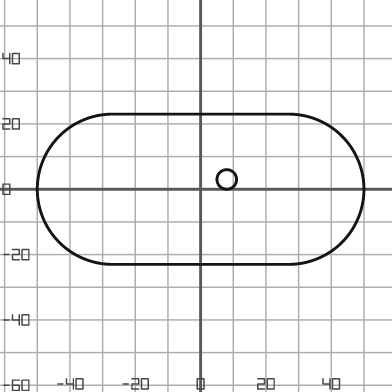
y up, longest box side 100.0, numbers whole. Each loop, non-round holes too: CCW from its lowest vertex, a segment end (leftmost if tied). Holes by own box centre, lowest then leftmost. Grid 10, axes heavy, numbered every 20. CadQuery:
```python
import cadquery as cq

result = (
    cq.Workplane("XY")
    .moveTo(-27.0, -23.0)
    .lineTo(27.0, -23.0)
    .threePointArc((50.0, 0.0), (27.0, 23.0))
    .lineTo(-27.0, 23.0)
    .threePointArc((-50.0, 0.0), (-27.0, -23.0))
    .close()
    .moveTo(8.0, 3.0)
    .circle(3.0)
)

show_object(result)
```